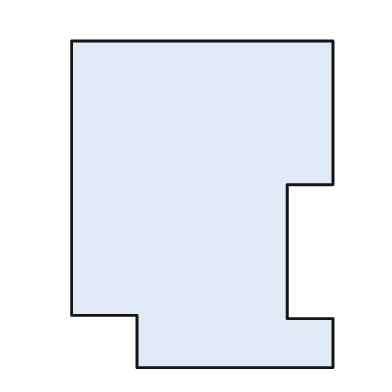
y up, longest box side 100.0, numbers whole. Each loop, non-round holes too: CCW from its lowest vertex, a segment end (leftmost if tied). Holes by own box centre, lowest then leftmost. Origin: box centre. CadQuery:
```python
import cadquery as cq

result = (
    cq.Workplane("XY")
    .moveTo(-20.0, -50.0)
    .lineTo(40.0, -50.0)
    .lineTo(40.0, -35.0)
    .lineTo(26.0, -35.0)
    .lineTo(26.0, 6.0)
    .lineTo(40.0, 6.0)
    .lineTo(40.0, 50.0)
    .lineTo(-40.0, 50.0)
    .lineTo(-40.0, -34.0)
    .lineTo(-20.0, -34.0)
    .close()
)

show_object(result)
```